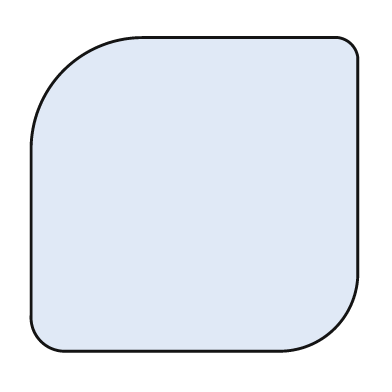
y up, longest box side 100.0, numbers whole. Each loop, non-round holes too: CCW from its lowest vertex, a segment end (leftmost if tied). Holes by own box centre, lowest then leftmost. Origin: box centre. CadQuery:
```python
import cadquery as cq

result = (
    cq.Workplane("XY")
    .moveTo(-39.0, -48.0)
    .lineTo(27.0, -48.0)
    .threePointArc((43.0, -41.0), (50.0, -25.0))
    .lineTo(50.0, 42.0)
    .threePointArc((48.0, 46.0), (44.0, 48.0))
    .lineTo(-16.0, 48.0)
    .threePointArc((-40.0, 38.0), (-50.0, 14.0))
    .lineTo(-50.0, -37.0)
    .threePointArc((-47.0, -45.0), (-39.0, -48.0))
    .close()
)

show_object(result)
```